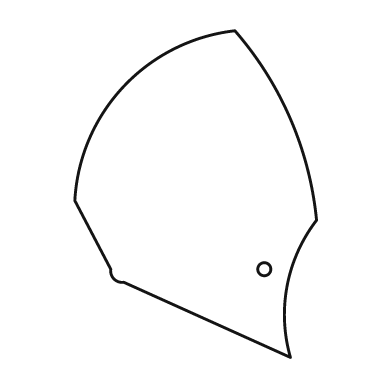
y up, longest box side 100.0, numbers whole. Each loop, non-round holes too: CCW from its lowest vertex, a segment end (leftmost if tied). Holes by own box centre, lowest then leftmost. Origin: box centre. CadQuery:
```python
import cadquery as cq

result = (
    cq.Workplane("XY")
    .moveTo(29.0, -50.0)
    .threePointArc((28.0, -28.0), (37.0, -8.0))
    .threePointArc((29.0, 23.0), (12.0, 50.0))
    .threePointArc((-22.0, 33.0), (-37.0, -2.0))
    .lineTo(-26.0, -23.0)
    .threePointArc((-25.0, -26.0), (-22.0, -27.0))
    .close()
    .moveTo(21.0, -23.0)
    .circle(2.0)
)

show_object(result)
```